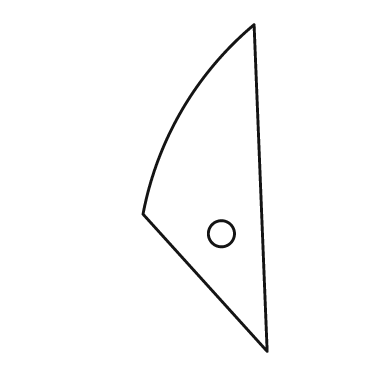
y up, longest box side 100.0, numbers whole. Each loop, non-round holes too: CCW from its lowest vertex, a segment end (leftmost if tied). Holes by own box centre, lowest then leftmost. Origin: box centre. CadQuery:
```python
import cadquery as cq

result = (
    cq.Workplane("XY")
    .moveTo(19.0, -50.0)
    .lineTo(15.0, 50.0)
    .threePointArc((-7.0, 24.0), (-19.0, -8.0))
    .close()
    .moveTo(5.0, -14.0)
    .circle(4.0)
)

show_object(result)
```